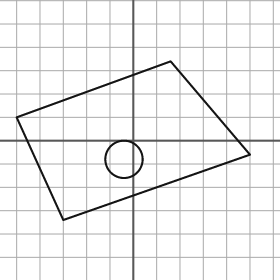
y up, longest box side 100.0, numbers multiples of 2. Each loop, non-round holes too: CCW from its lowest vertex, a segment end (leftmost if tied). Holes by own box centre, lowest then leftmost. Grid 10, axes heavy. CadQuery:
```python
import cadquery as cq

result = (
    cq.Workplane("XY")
    .moveTo(-30.0, -34.0)
    .lineTo(50.0, -6.0)
    .lineTo(16.0, 34.0)
    .lineTo(-50.0, 10.0)
    .close()
    .moveTo(-4.0, -8.0)
    .circle(8.0)
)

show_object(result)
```